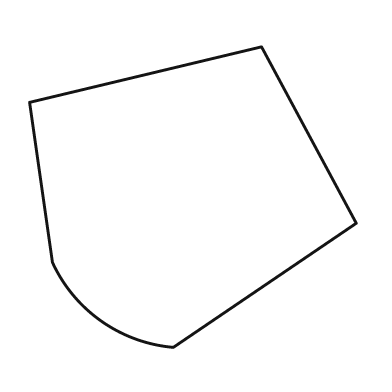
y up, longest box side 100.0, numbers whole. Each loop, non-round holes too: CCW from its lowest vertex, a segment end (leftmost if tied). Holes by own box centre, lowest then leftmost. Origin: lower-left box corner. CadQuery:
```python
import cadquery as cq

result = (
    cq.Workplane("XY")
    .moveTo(44.0, 0.0)
    .lineTo(100.0, 38.0)
    .lineTo(71.0, 92.0)
    .lineTo(0.0, 75.0)
    .lineTo(7.0, 26.0)
    .threePointArc((22.0, 8.0), (44.0, 0.0))
    .close()
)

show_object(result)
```